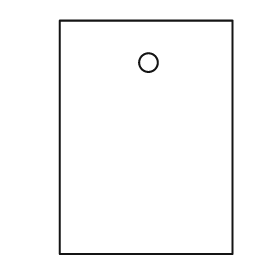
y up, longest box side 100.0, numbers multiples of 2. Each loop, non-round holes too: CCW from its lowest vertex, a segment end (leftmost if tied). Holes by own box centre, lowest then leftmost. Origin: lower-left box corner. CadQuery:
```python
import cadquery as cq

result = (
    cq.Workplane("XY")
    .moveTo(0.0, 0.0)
    .lineTo(74.0, 0.0)
    .lineTo(74.0, 100.0)
    .lineTo(0.0, 100.0)
    .close()
    .moveTo(38.0, 82.0)
    .circle(4.0)
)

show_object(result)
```